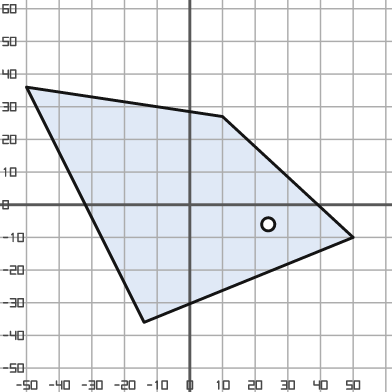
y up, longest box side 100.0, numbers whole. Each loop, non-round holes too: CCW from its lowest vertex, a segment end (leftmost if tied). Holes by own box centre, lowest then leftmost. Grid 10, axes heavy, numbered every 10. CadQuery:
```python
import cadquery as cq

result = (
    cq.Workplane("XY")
    .moveTo(-14.0, -36.0)
    .lineTo(50.0, -10.0)
    .lineTo(10.0, 27.0)
    .lineTo(-50.0, 36.0)
    .close()
    .moveTo(24.0, -6.0)
    .circle(2.0)
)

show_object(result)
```